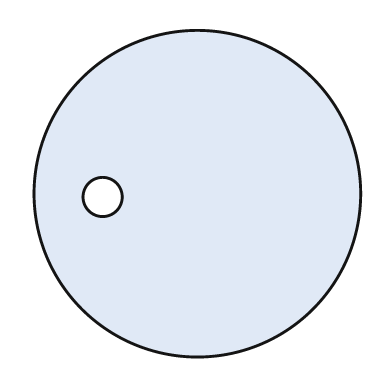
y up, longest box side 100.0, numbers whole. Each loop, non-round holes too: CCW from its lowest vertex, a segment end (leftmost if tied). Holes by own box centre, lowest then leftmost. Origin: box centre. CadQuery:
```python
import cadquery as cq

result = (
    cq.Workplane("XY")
    .moveTo(0.0, 0.0)
    .circle(50.0)
    .moveTo(-29.0, -1.0)
    .circle(6.0)
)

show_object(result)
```